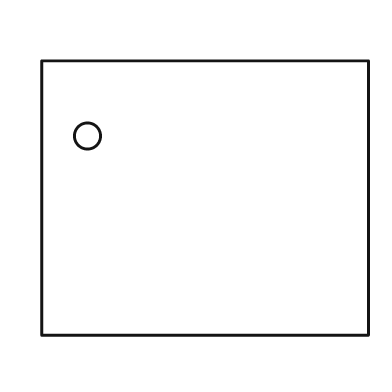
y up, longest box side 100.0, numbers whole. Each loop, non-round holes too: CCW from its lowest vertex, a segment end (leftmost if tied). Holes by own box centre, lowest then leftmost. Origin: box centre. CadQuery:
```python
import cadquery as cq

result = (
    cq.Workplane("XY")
    .moveTo(-50.0, -42.0)
    .lineTo(50.0, -42.0)
    .lineTo(50.0, 42.0)
    .lineTo(-50.0, 42.0)
    .close()
    .moveTo(-36.0, 19.0)
    .circle(4.0)
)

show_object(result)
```